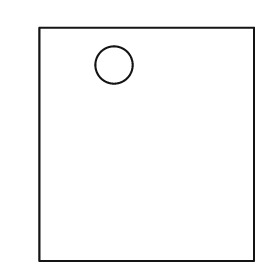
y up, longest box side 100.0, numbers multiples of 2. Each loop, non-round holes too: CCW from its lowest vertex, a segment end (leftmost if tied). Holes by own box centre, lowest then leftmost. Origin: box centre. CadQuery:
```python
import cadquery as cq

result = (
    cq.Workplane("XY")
    .moveTo(-46.0, -50.0)
    .lineTo(46.0, -50.0)
    .lineTo(46.0, 50.0)
    .lineTo(-46.0, 50.0)
    .close()
    .moveTo(-14.0, 34.0)
    .circle(8.0)
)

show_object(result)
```